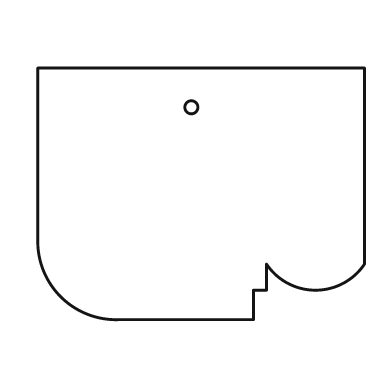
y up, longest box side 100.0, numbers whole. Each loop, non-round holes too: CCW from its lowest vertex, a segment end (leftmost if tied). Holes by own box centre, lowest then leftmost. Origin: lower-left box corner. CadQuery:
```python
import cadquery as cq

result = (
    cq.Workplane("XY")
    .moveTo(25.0, 0.0)
    .lineTo(66.0, 0.0)
    .lineTo(66.0, 9.0)
    .lineTo(70.0, 9.0)
    .lineTo(70.0, 17.0)
    .threePointArc((85.0, 9.0), (100.0, 17.0))
    .lineTo(100.0, 77.0)
    .lineTo(0.0, 77.0)
    .lineTo(0.0, 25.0)
    .threePointArc((7.0, 7.0), (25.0, 0.0))
    .close()
    .moveTo(47.0, 65.0)
    .circle(2.0)
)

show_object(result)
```